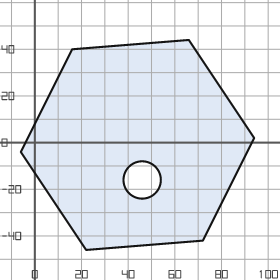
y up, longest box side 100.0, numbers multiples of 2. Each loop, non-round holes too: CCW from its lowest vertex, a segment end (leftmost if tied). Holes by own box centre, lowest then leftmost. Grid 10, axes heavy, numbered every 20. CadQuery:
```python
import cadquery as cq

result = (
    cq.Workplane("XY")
    .moveTo(22.0, -46.0)
    .lineTo(72.0, -42.0)
    .lineTo(94.0, 2.0)
    .lineTo(66.0, 44.0)
    .lineTo(16.0, 40.0)
    .lineTo(-6.0, -4.0)
    .close()
    .moveTo(46.0, -16.0)
    .circle(8.0)
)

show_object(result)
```